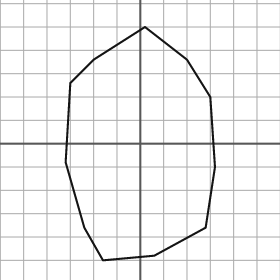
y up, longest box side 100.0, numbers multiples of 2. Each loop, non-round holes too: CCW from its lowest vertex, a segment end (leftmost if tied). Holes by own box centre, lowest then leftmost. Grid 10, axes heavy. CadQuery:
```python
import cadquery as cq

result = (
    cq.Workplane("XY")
    .moveTo(-16.0, -50.0)
    .lineTo(6.0, -48.0)
    .lineTo(28.0, -36.0)
    .lineTo(32.0, -10.0)
    .lineTo(30.0, 20.0)
    .lineTo(20.0, 36.0)
    .lineTo(2.0, 50.0)
    .lineTo(-20.0, 36.0)
    .lineTo(-30.0, 26.0)
    .lineTo(-32.0, -8.0)
    .lineTo(-24.0, -36.0)
    .close()
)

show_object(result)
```